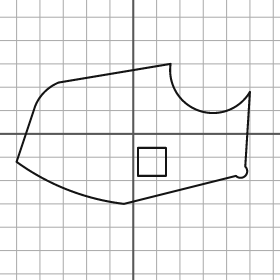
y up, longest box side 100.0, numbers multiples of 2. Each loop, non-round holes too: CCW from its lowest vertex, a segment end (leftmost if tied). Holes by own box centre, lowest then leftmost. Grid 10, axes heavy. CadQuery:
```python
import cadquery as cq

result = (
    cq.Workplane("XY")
    .moveTo(-4.0, -30.0)
    .lineTo(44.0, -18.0)
    .threePointArc((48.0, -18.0), (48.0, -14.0))
    .lineTo(50.0, 18.0)
    .threePointArc((28.0, 10.0), (16.0, 30.0))
    .lineTo(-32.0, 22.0)
    .threePointArc((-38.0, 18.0), (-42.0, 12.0))
    .lineTo(-50.0, -12.0)
    .threePointArc((-28.0, -24.0), (-4.0, -30.0))
    .close()
    .moveTo(2.0, -18.0)
    .lineTo(14.0, -18.0)
    .lineTo(14.0, -6.0)
    .lineTo(2.0, -6.0)
    .close()
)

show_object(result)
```